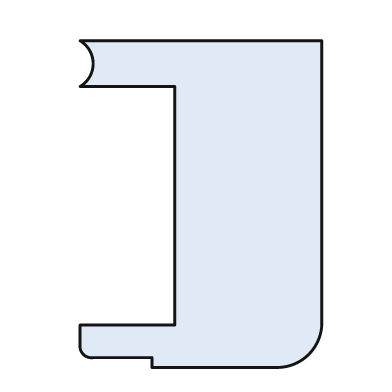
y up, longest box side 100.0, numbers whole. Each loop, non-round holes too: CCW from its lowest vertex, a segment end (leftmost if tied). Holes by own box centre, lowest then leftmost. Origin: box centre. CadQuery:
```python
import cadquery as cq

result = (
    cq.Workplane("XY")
    .moveTo(-15.0, -50.0)
    .lineTo(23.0, -50.0)
    .threePointArc((33.0, -46.0), (37.0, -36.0))
    .lineTo(37.0, 50.0)
    .lineTo(-37.0, 50.0)
    .threePointArc((-33.0, 43.0), (-37.0, 36.0))
    .lineTo(-8.0, 36.0)
    .lineTo(-8.0, -37.0)
    .lineTo(-37.0, -37.0)
    .lineTo(-37.0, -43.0)
    .threePointArc((-36.0, -46.0), (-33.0, -47.0))
    .lineTo(-15.0, -47.0)
    .close()
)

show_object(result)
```